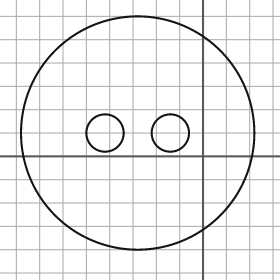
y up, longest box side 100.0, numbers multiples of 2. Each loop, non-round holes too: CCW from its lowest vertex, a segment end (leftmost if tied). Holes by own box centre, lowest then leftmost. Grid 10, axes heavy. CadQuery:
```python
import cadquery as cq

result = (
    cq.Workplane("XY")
    .moveTo(-28.0, 10.0)
    .circle(50.0)
    .moveTo(-42.0, 10.0)
    .circle(8.0)
    .moveTo(-14.0, 10.0)
    .circle(8.0)
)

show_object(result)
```